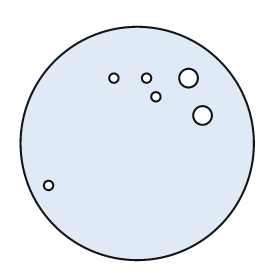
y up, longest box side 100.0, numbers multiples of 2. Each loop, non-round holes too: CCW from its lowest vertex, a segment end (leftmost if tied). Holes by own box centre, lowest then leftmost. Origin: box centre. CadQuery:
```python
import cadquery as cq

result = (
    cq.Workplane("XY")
    .moveTo(0.0, 0.0)
    .circle(50.0)
    .moveTo(-38.0, -18.0)
    .circle(2.0)
    .moveTo(28.0, 12.0)
    .circle(4.0)
    .moveTo(8.0, 20.0)
    .circle(2.0)
    .moveTo(-10.0, 28.0)
    .circle(2.0)
    .moveTo(4.0, 28.0)
    .circle(2.0)
    .moveTo(22.0, 28.0)
    .circle(4.0)
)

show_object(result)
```